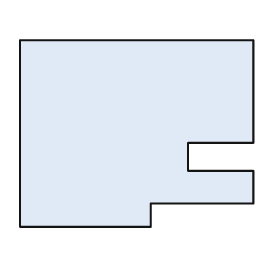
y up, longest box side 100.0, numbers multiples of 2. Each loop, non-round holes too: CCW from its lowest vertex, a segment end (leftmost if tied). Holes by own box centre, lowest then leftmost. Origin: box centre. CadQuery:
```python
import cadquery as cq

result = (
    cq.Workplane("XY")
    .moveTo(-50.0, -40.0)
    .lineTo(6.0, -40.0)
    .lineTo(6.0, -30.0)
    .lineTo(50.0, -30.0)
    .lineTo(50.0, -16.0)
    .lineTo(22.0, -16.0)
    .lineTo(22.0, -4.0)
    .lineTo(50.0, -4.0)
    .lineTo(50.0, 40.0)
    .lineTo(-50.0, 40.0)
    .close()
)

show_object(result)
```